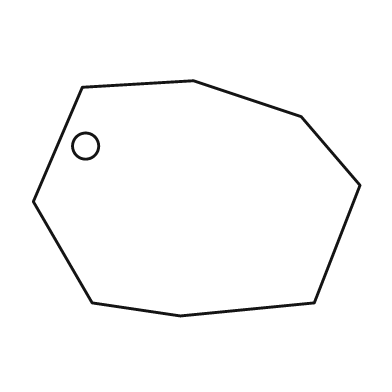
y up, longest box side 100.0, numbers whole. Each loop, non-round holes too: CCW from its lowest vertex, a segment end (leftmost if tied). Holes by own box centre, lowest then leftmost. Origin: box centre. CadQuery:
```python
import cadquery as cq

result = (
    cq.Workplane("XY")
    .moveTo(-5.0, -36.0)
    .lineTo(36.0, -32.0)
    .lineTo(50.0, 4.0)
    .lineTo(32.0, 25.0)
    .lineTo(-1.0, 36.0)
    .lineTo(-35.0, 34.0)
    .lineTo(-50.0, -1.0)
    .lineTo(-32.0, -32.0)
    .close()
    .moveTo(-34.0, 16.0)
    .circle(4.0)
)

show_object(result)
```